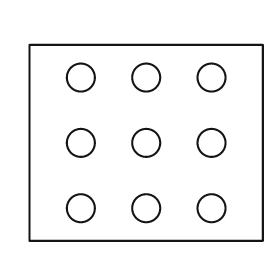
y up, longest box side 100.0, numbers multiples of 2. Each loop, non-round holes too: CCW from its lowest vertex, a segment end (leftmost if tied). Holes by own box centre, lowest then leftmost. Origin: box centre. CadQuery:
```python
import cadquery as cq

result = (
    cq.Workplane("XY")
    .moveTo(-50.0, -42.0)
    .lineTo(50.0, -42.0)
    .lineTo(50.0, 42.0)
    .lineTo(-50.0, 42.0)
    .close()
    .moveTo(-28.0, -28.0)
    .circle(6.0)
    .moveTo(0.0, -28.0)
    .circle(6.0)
    .moveTo(28.0, -28.0)
    .circle(6.0)
    .moveTo(-28.0, 0.0)
    .circle(6.0)
    .moveTo(0.0, 0.0)
    .circle(6.0)
    .moveTo(28.0, 0.0)
    .circle(6.0)
    .moveTo(-28.0, 28.0)
    .circle(6.0)
    .moveTo(0.0, 28.0)
    .circle(6.0)
    .moveTo(28.0, 28.0)
    .circle(6.0)
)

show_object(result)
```